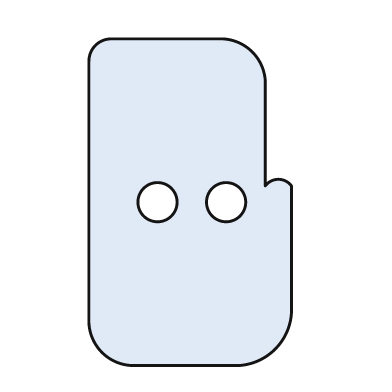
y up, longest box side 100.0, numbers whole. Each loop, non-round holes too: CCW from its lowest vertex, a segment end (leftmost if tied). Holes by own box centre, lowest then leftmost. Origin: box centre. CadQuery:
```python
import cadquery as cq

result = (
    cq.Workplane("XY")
    .moveTo(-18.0, -50.0)
    .lineTo(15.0, -50.0)
    .threePointArc((26.0, -45.0), (31.0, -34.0))
    .lineTo(31.0, 5.0)
    .threePointArc((27.0, 7.0), (23.0, 5.0))
    .lineTo(23.0, 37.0)
    .threePointArc((19.0, 46.0), (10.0, 50.0))
    .lineTo(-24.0, 50.0)
    .threePointArc((-29.0, 48.0), (-31.0, 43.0))
    .lineTo(-31.0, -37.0)
    .threePointArc((-27.0, -46.0), (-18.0, -50.0))
    .close()
    .moveTo(-10.0, 0.0)
    .circle(6.0)
    .moveTo(11.0, 0.0)
    .circle(6.0)
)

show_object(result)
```